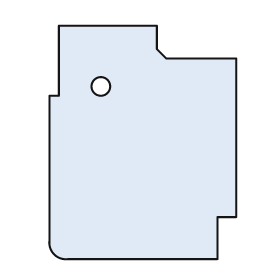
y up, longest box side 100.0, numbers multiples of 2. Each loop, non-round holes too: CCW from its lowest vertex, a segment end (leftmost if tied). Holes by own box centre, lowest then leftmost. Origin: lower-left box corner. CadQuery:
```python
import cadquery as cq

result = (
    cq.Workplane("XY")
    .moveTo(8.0, 0.0)
    .lineTo(72.0, 0.0)
    .lineTo(72.0, 18.0)
    .lineTo(80.0, 18.0)
    .lineTo(80.0, 86.0)
    .lineTo(50.0, 86.0)
    .lineTo(46.0, 90.0)
    .lineTo(46.0, 100.0)
    .lineTo(4.0, 100.0)
    .lineTo(4.0, 70.0)
    .lineTo(0.0, 70.0)
    .lineTo(0.0, 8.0)
    .threePointArc((2.0, 2.0), (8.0, 0.0))
    .close()
    .moveTo(22.0, 74.0)
    .circle(4.0)
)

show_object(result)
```